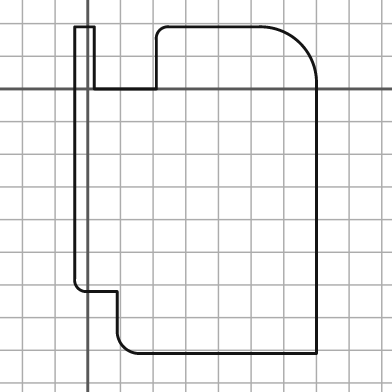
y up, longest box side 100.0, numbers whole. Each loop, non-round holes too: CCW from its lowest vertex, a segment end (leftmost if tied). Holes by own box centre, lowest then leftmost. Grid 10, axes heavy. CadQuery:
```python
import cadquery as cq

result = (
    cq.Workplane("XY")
    .moveTo(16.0, -81.0)
    .lineTo(70.0, -81.0)
    .lineTo(70.0, 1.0)
    .threePointArc((65.0, 14.0), (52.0, 19.0))
    .lineTo(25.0, 19.0)
    .threePointArc((22.0, 18.0), (21.0, 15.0))
    .lineTo(21.0, 0.0)
    .lineTo(2.0, 0.0)
    .lineTo(2.0, 19.0)
    .lineTo(-4.0, 19.0)
    .lineTo(-4.0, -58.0)
    .threePointArc((-3.0, -61.0), (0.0, -62.0))
    .lineTo(9.0, -62.0)
    .lineTo(9.0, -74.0)
    .threePointArc((11.0, -79.0), (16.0, -81.0))
    .close()
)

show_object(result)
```